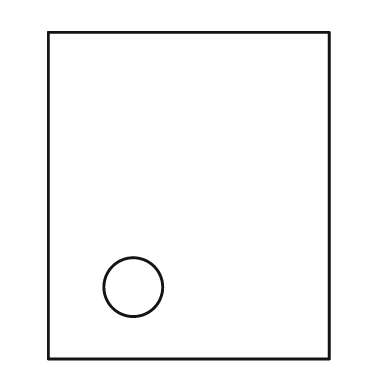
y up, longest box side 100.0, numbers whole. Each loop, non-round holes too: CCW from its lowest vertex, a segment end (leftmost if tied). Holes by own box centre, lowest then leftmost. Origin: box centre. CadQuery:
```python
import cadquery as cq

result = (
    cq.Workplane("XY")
    .moveTo(-43.0, -50.0)
    .lineTo(43.0, -50.0)
    .lineTo(43.0, 50.0)
    .lineTo(-43.0, 50.0)
    .close()
    .moveTo(-17.0, -28.0)
    .circle(9.0)
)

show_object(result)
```